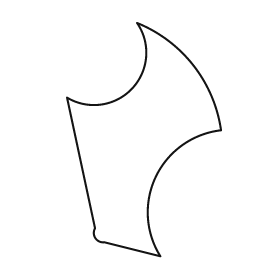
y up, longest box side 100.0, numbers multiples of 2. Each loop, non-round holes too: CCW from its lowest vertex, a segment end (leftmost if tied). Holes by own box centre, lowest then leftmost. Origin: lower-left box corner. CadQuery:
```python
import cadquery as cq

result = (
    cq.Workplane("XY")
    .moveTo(40.0, 0.0)
    .threePointArc((38.0, 34.0), (66.0, 54.0))
    .threePointArc((54.0, 82.0), (30.0, 100.0))
    .threePointArc((28.0, 72.0), (0.0, 68.0))
    .lineTo(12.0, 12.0)
    .threePointArc((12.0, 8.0), (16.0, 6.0))
    .close()
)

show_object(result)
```